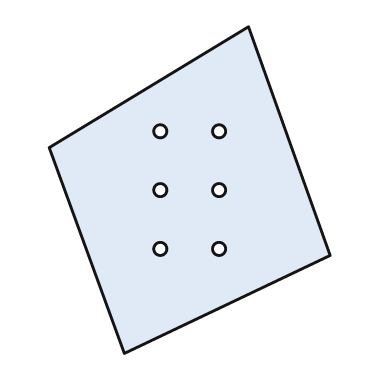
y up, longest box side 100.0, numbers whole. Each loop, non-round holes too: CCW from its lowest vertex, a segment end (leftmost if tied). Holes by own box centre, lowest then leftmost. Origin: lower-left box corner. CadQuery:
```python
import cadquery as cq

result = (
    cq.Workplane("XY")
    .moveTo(23.0, 0.0)
    .lineTo(86.0, 30.0)
    .lineTo(61.0, 100.0)
    .lineTo(0.0, 63.0)
    .close()
    .moveTo(34.0, 32.0)
    .circle(2.0)
    .moveTo(52.0, 32.0)
    .circle(2.0)
    .moveTo(34.0, 50.0)
    .circle(2.0)
    .moveTo(52.0, 50.0)
    .circle(2.0)
    .moveTo(34.0, 68.0)
    .circle(2.0)
    .moveTo(52.0, 68.0)
    .circle(2.0)
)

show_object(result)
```